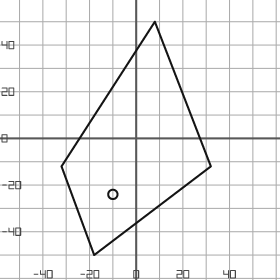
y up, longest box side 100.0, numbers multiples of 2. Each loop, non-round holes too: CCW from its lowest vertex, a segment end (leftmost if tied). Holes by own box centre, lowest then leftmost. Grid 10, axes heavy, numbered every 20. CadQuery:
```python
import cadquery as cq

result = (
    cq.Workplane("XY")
    .moveTo(-18.0, -50.0)
    .lineTo(32.0, -12.0)
    .lineTo(8.0, 50.0)
    .lineTo(-32.0, -12.0)
    .close()
    .moveTo(-10.0, -24.0)
    .circle(2.0)
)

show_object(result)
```